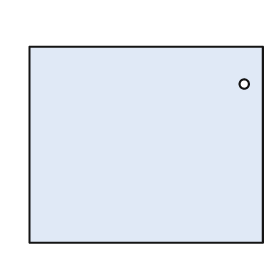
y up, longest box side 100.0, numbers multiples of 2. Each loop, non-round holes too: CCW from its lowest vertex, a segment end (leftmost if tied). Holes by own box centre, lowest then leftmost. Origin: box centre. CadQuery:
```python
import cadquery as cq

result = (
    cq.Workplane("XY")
    .moveTo(-50.0, -42.0)
    .lineTo(50.0, -42.0)
    .lineTo(50.0, 42.0)
    .lineTo(-50.0, 42.0)
    .close()
    .moveTo(42.0, 26.0)
    .circle(2.0)
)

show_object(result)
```